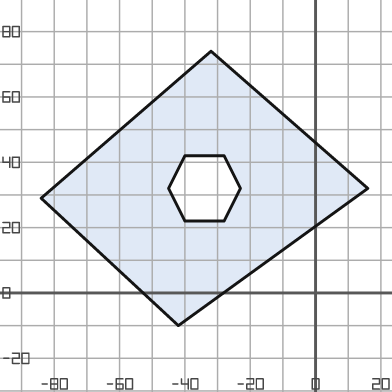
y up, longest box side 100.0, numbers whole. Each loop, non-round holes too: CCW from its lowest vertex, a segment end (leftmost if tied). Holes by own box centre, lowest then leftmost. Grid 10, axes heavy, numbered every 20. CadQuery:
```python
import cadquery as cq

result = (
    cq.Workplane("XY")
    .moveTo(-42.0, -10.0)
    .lineTo(16.0, 32.0)
    .lineTo(-32.0, 74.0)
    .lineTo(-84.0, 29.0)
    .close()
    .moveTo(-40.0, 22.0)
    .lineTo(-28.0, 22.0)
    .lineTo(-23.0, 32.0)
    .lineTo(-28.0, 42.0)
    .lineTo(-40.0, 42.0)
    .lineTo(-45.0, 32.0)
    .close()
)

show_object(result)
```